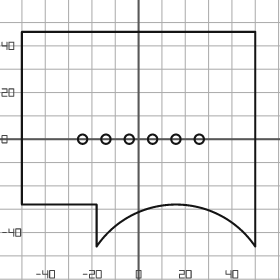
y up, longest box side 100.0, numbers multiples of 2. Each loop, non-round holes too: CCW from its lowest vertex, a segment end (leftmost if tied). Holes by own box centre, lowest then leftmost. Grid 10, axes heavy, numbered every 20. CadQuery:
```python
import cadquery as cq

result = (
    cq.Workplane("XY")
    .moveTo(-18.0, -46.0)
    .threePointArc((16.0, -28.0), (50.0, -46.0))
    .lineTo(50.0, 46.0)
    .lineTo(-50.0, 46.0)
    .lineTo(-50.0, -28.0)
    .lineTo(-18.0, -28.0)
    .close()
    .moveTo(-24.0, 0.0)
    .circle(2.0)
    .moveTo(-14.0, 0.0)
    .circle(2.0)
    .moveTo(-4.0, 0.0)
    .circle(2.0)
    .moveTo(6.0, 0.0)
    .circle(2.0)
    .moveTo(16.0, 0.0)
    .circle(2.0)
    .moveTo(26.0, 0.0)
    .circle(2.0)
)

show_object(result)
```